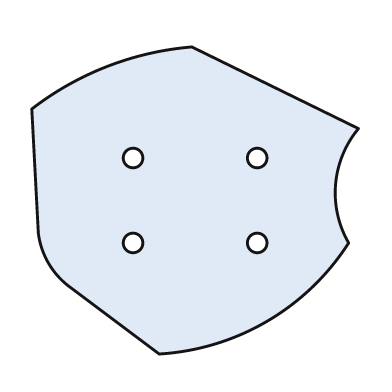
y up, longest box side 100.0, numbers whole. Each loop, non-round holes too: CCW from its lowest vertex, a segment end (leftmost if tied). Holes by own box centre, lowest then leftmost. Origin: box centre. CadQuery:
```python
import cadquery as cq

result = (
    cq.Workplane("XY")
    .moveTo(-11.0, -47.0)
    .threePointArc((22.0, -37.0), (47.0, -13.0))
    .threePointArc((43.0, 5.0), (50.0, 22.0))
    .lineTo(-1.0, 47.0)
    .threePointArc((-27.0, 41.0), (-50.0, 28.0))
    .lineTo(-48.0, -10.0)
    .threePointArc((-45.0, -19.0), (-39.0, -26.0))
    .close()
    .moveTo(-19.0, -13.0)
    .circle(3.0)
    .moveTo(19.0, -13.0)
    .circle(3.0)
    .moveTo(-19.0, 13.0)
    .circle(3.0)
    .moveTo(19.0, 13.0)
    .circle(3.0)
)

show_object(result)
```